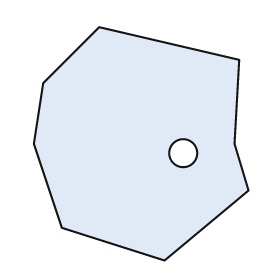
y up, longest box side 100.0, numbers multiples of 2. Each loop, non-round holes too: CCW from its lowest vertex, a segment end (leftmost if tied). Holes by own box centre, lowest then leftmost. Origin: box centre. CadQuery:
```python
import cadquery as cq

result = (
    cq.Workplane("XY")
    .moveTo(10.0, -50.0)
    .lineTo(46.0, -20.0)
    .lineTo(40.0, 0.0)
    .lineTo(42.0, 36.0)
    .lineTo(-18.0, 50.0)
    .lineTo(-42.0, 26.0)
    .lineTo(-46.0, 0.0)
    .lineTo(-34.0, -36.0)
    .close()
    .moveTo(18.0, -4.0)
    .circle(6.0)
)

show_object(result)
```